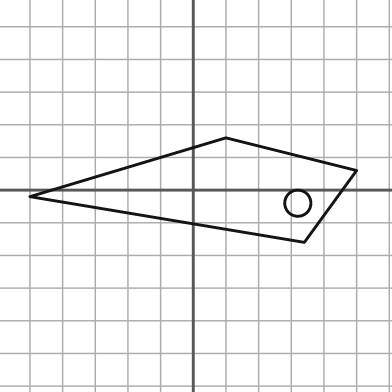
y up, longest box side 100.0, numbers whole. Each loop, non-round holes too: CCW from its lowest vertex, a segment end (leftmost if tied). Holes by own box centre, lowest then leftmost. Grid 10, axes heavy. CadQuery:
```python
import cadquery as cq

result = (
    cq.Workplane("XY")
    .moveTo(34.0, -16.0)
    .lineTo(50.0, 6.0)
    .lineTo(10.0, 16.0)
    .lineTo(-50.0, -2.0)
    .close()
    .moveTo(32.0, -4.0)
    .circle(4.0)
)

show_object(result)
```